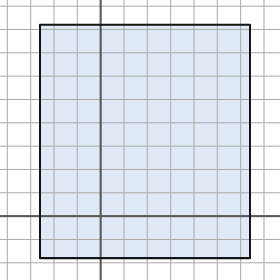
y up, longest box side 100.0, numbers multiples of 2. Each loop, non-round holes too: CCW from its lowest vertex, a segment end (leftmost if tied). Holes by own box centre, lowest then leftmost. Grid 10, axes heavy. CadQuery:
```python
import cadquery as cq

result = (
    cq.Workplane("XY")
    .moveTo(-26.0, -18.0)
    .lineTo(64.0, -18.0)
    .lineTo(64.0, 82.0)
    .lineTo(-26.0, 82.0)
    .close()
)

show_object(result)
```